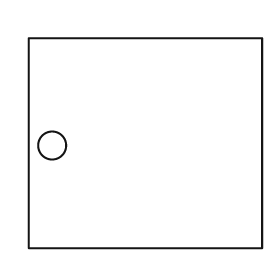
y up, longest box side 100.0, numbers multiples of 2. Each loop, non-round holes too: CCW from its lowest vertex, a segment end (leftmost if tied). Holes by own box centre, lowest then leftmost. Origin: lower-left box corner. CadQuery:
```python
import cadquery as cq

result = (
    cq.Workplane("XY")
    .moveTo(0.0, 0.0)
    .lineTo(100.0, 0.0)
    .lineTo(100.0, 90.0)
    .lineTo(0.0, 90.0)
    .close()
    .moveTo(10.0, 44.0)
    .circle(6.0)
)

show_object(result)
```